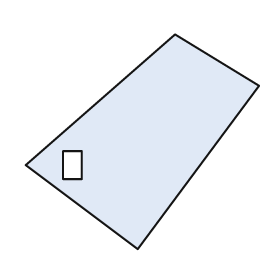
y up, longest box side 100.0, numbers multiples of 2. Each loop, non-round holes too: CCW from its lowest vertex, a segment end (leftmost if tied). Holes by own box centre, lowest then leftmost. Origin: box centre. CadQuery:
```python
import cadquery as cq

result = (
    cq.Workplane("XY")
    .moveTo(-2.0, -46.0)
    .lineTo(50.0, 24.0)
    .lineTo(14.0, 46.0)
    .lineTo(-50.0, -10.0)
    .close()
    .moveTo(-34.0, -16.0)
    .lineTo(-26.0, -16.0)
    .lineTo(-26.0, -4.0)
    .lineTo(-34.0, -4.0)
    .close()
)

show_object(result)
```